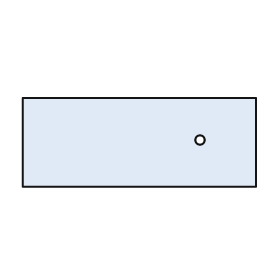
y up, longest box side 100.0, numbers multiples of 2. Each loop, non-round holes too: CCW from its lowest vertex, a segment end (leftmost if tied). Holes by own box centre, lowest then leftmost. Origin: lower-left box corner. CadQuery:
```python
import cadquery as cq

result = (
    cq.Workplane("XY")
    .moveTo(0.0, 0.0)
    .lineTo(100.0, 0.0)
    .lineTo(100.0, 38.0)
    .lineTo(0.0, 38.0)
    .close()
    .moveTo(76.0, 20.0)
    .circle(2.0)
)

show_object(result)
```